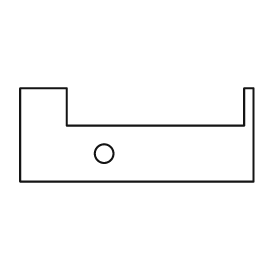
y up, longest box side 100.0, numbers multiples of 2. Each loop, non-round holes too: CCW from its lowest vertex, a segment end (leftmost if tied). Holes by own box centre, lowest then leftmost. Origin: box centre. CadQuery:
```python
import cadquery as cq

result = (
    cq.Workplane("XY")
    .moveTo(-50.0, -20.0)
    .lineTo(50.0, -20.0)
    .lineTo(50.0, 20.0)
    .lineTo(46.0, 20.0)
    .lineTo(46.0, 4.0)
    .lineTo(-30.0, 4.0)
    .lineTo(-30.0, 20.0)
    .lineTo(-50.0, 20.0)
    .close()
    .moveTo(-14.0, -8.0)
    .circle(4.0)
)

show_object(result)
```